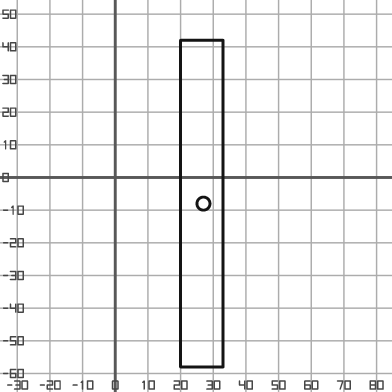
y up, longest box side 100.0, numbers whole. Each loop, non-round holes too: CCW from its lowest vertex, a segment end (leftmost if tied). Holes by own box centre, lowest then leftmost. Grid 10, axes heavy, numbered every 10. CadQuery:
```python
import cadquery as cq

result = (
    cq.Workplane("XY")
    .moveTo(20.0, -58.0)
    .lineTo(33.0, -58.0)
    .lineTo(33.0, 42.0)
    .lineTo(20.0, 42.0)
    .close()
    .moveTo(27.0, -8.0)
    .circle(2.0)
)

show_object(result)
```